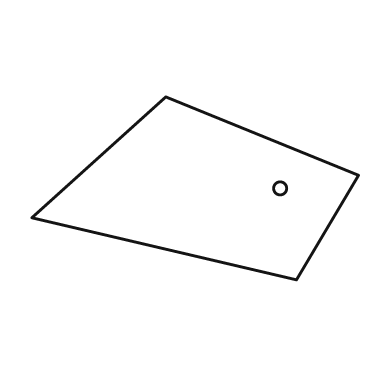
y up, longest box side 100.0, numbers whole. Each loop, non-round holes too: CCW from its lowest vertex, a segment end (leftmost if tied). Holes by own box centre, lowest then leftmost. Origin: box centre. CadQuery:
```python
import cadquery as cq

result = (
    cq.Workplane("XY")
    .moveTo(31.0, -28.0)
    .lineTo(50.0, 4.0)
    .lineTo(-9.0, 28.0)
    .lineTo(-50.0, -9.0)
    .close()
    .moveTo(26.0, 0.0)
    .circle(2.0)
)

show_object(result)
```